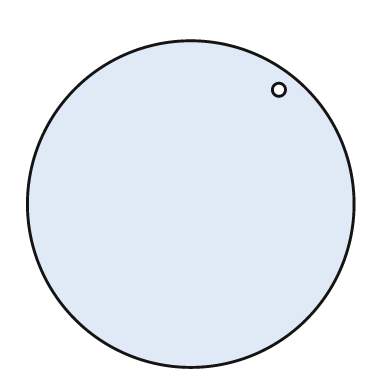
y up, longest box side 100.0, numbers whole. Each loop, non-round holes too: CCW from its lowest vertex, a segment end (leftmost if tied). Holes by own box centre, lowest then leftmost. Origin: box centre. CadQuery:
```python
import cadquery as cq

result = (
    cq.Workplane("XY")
    .moveTo(0.0, 0.0)
    .circle(50.0)
    .moveTo(27.0, 35.0)
    .circle(2.0)
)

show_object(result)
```